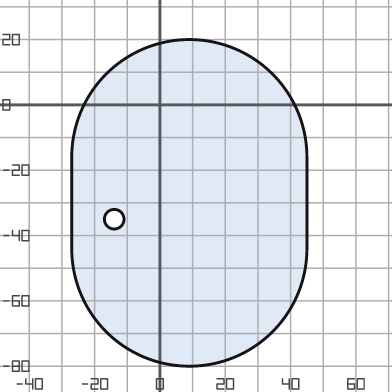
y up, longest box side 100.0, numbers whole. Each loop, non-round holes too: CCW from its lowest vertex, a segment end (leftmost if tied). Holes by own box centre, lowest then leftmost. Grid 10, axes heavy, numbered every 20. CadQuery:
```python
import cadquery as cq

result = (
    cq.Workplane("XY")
    .moveTo(-27.0, -44.0)
    .threePointArc((9.0, -80.0), (45.0, -44.0))
    .lineTo(45.0, -16.0)
    .threePointArc((9.0, 20.0), (-27.0, -16.0))
    .close()
    .moveTo(-14.0, -35.0)
    .circle(3.0)
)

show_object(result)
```